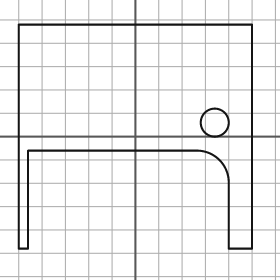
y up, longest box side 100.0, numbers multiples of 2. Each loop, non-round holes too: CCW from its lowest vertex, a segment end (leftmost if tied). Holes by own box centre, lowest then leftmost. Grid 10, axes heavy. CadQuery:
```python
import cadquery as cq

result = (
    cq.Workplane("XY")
    .moveTo(-50.0, -48.0)
    .lineTo(-46.0, -48.0)
    .lineTo(-46.0, -6.0)
    .lineTo(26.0, -6.0)
    .threePointArc((36.0, -10.0), (40.0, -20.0))
    .lineTo(40.0, -48.0)
    .lineTo(50.0, -48.0)
    .lineTo(50.0, 48.0)
    .lineTo(-50.0, 48.0)
    .close()
    .moveTo(34.0, 6.0)
    .circle(6.0)
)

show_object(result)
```